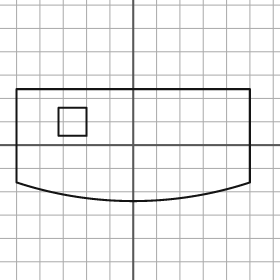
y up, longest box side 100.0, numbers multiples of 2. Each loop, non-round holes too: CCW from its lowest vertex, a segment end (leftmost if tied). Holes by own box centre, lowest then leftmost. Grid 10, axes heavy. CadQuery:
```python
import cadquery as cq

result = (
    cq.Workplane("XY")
    .moveTo(-50.0, -16.0)
    .threePointArc((0.0, -24.0), (50.0, -16.0))
    .lineTo(50.0, 24.0)
    .lineTo(-50.0, 24.0)
    .close()
    .moveTo(-32.0, 4.0)
    .lineTo(-20.0, 4.0)
    .lineTo(-20.0, 16.0)
    .lineTo(-32.0, 16.0)
    .close()
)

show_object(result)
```